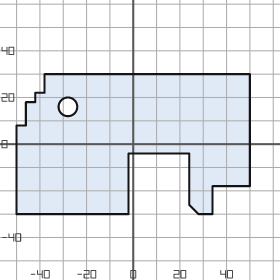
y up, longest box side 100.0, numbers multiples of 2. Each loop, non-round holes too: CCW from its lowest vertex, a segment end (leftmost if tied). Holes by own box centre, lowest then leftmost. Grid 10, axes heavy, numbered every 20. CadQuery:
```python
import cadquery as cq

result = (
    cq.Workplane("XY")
    .moveTo(-50.0, -30.0)
    .lineTo(-2.0, -30.0)
    .lineTo(-2.0, -4.0)
    .lineTo(24.0, -4.0)
    .lineTo(24.0, -26.0)
    .lineTo(28.0, -30.0)
    .lineTo(34.0, -30.0)
    .lineTo(34.0, -18.0)
    .lineTo(50.0, -18.0)
    .lineTo(50.0, 30.0)
    .lineTo(-38.0, 30.0)
    .lineTo(-38.0, 22.0)
    .lineTo(-42.0, 22.0)
    .lineTo(-42.0, 18.0)
    .lineTo(-46.0, 18.0)
    .lineTo(-46.0, 8.0)
    .lineTo(-50.0, 8.0)
    .close()
    .moveTo(-28.0, 16.0)
    .circle(4.0)
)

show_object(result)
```